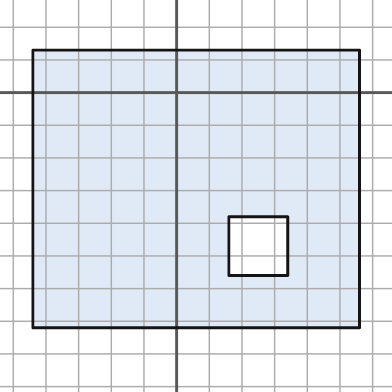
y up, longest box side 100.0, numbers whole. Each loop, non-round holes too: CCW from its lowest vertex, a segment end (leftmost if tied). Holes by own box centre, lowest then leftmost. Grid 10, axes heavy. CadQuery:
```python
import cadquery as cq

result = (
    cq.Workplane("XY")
    .moveTo(-44.0, -72.0)
    .lineTo(56.0, -72.0)
    .lineTo(56.0, 13.0)
    .lineTo(-44.0, 13.0)
    .close()
    .moveTo(16.0, -56.0)
    .lineTo(34.0, -56.0)
    .lineTo(34.0, -38.0)
    .lineTo(16.0, -38.0)
    .close()
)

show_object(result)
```